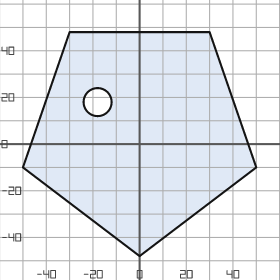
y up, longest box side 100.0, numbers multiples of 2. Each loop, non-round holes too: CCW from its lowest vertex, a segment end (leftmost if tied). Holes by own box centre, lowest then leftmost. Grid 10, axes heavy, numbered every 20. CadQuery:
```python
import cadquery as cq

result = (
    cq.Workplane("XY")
    .moveTo(0.0, -48.0)
    .lineTo(50.0, -10.0)
    .lineTo(30.0, 48.0)
    .lineTo(-30.0, 48.0)
    .lineTo(-50.0, -10.0)
    .close()
    .moveTo(-18.0, 18.0)
    .circle(6.0)
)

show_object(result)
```